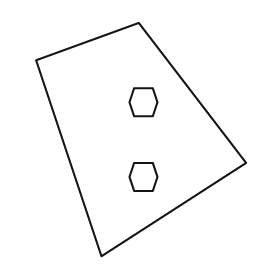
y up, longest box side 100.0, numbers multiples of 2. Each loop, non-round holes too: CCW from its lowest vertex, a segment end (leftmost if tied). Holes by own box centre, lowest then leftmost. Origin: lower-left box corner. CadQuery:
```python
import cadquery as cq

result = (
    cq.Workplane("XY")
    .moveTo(28.0, 0.0)
    .lineTo(90.0, 40.0)
    .lineTo(44.0, 100.0)
    .lineTo(0.0, 84.0)
    .close()
    .moveTo(42.0, 28.0)
    .lineTo(50.0, 28.0)
    .lineTo(52.0, 34.0)
    .lineTo(50.0, 40.0)
    .lineTo(42.0, 40.0)
    .lineTo(40.0, 34.0)
    .close()
    .moveTo(42.0, 60.0)
    .lineTo(50.0, 60.0)
    .lineTo(52.0, 66.0)
    .lineTo(50.0, 72.0)
    .lineTo(42.0, 72.0)
    .lineTo(40.0, 66.0)
    .close()
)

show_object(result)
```